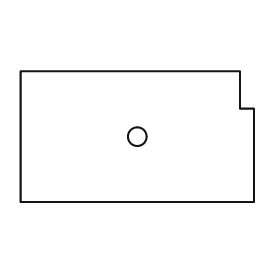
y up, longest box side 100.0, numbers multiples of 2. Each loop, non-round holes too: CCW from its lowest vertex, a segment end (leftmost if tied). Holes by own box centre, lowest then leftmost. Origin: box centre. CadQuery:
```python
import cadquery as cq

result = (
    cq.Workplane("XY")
    .moveTo(-50.0, -28.0)
    .lineTo(50.0, -28.0)
    .lineTo(50.0, 12.0)
    .lineTo(44.0, 12.0)
    .lineTo(44.0, 28.0)
    .lineTo(-50.0, 28.0)
    .close()
    .moveTo(0.0, 0.0)
    .circle(4.0)
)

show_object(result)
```